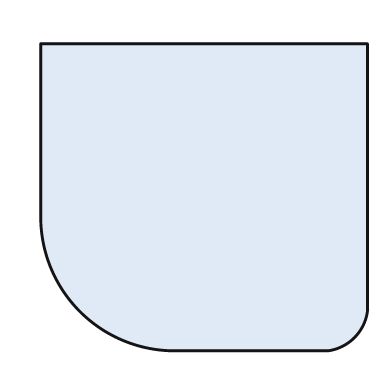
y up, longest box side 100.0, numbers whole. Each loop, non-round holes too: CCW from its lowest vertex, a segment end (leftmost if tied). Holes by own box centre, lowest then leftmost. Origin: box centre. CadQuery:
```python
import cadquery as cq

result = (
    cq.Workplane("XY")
    .moveTo(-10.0, -47.0)
    .lineTo(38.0, -47.0)
    .threePointArc((46.0, -43.0), (50.0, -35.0))
    .lineTo(50.0, 47.0)
    .lineTo(-50.0, 47.0)
    .lineTo(-50.0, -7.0)
    .threePointArc((-38.0, -35.0), (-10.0, -47.0))
    .close()
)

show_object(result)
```